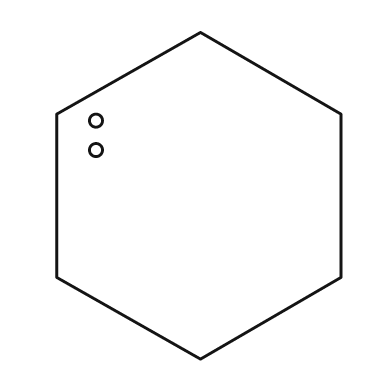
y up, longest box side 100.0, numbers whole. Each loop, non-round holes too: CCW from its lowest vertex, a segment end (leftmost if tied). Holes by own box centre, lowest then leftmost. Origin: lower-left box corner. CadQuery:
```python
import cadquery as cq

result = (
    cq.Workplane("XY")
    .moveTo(44.0, 0.0)
    .lineTo(87.0, 25.0)
    .lineTo(87.0, 75.0)
    .lineTo(44.0, 100.0)
    .lineTo(0.0, 75.0)
    .lineTo(0.0, 25.0)
    .close()
    .moveTo(12.0, 64.0)
    .circle(2.0)
    .moveTo(12.0, 73.0)
    .circle(2.0)
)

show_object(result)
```